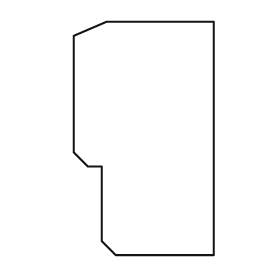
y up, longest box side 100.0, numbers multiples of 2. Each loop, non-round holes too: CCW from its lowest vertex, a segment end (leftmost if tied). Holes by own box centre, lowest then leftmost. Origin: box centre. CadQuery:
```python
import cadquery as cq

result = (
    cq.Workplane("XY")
    .moveTo(-12.0, -50.0)
    .lineTo(30.0, -50.0)
    .lineTo(30.0, 50.0)
    .lineTo(-16.0, 50.0)
    .lineTo(-30.0, 44.0)
    .lineTo(-30.0, -6.0)
    .lineTo(-24.0, -12.0)
    .lineTo(-18.0, -12.0)
    .lineTo(-18.0, -44.0)
    .close()
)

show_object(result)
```